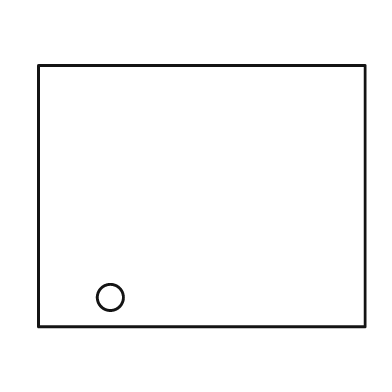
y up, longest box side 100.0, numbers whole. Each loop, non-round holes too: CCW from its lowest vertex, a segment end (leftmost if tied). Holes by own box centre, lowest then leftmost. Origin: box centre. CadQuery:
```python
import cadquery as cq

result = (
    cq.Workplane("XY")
    .moveTo(-50.0, -40.0)
    .lineTo(50.0, -40.0)
    .lineTo(50.0, 40.0)
    .lineTo(-50.0, 40.0)
    .close()
    .moveTo(-28.0, -31.0)
    .circle(4.0)
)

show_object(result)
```